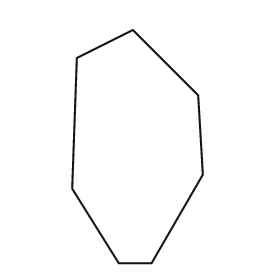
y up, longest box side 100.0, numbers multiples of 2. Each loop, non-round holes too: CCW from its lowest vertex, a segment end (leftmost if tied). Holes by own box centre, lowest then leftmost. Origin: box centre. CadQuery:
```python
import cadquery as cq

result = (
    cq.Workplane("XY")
    .moveTo(-8.0, -50.0)
    .lineTo(6.0, -50.0)
    .lineTo(28.0, -12.0)
    .lineTo(26.0, 22.0)
    .lineTo(-2.0, 50.0)
    .lineTo(-26.0, 38.0)
    .lineTo(-28.0, -18.0)
    .close()
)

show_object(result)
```